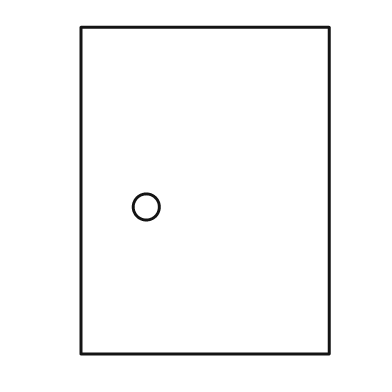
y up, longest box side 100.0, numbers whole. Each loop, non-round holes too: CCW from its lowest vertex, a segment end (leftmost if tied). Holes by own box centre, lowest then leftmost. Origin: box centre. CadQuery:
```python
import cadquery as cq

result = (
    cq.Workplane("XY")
    .moveTo(-38.0, -50.0)
    .lineTo(38.0, -50.0)
    .lineTo(38.0, 50.0)
    .lineTo(-38.0, 50.0)
    .close()
    .moveTo(-18.0, -5.0)
    .circle(4.0)
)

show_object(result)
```